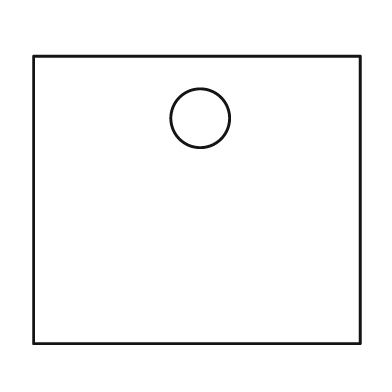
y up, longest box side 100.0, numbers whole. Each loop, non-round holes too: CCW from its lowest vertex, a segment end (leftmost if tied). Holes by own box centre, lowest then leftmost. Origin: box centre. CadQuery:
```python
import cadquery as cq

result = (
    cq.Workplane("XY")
    .moveTo(-50.0, -44.0)
    .lineTo(50.0, -44.0)
    .lineTo(50.0, 44.0)
    .lineTo(-50.0, 44.0)
    .close()
    .moveTo(1.0, 25.0)
    .circle(9.0)
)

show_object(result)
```